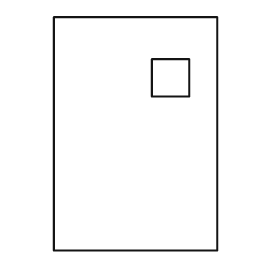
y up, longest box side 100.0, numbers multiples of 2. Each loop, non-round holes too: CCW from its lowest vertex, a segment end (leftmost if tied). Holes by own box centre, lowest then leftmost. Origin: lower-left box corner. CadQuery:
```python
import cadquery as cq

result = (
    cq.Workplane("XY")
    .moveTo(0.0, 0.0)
    .lineTo(70.0, 0.0)
    .lineTo(70.0, 100.0)
    .lineTo(0.0, 100.0)
    .close()
    .moveTo(42.0, 66.0)
    .lineTo(58.0, 66.0)
    .lineTo(58.0, 82.0)
    .lineTo(42.0, 82.0)
    .close()
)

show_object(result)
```